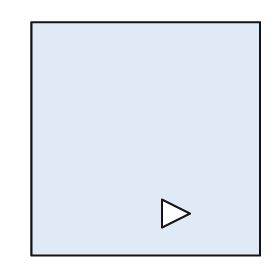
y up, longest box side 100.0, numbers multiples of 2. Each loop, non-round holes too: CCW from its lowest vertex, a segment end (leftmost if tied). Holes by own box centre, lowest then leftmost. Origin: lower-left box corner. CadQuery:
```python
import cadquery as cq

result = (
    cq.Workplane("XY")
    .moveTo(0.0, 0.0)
    .lineTo(98.0, 0.0)
    .lineTo(98.0, 100.0)
    .lineTo(0.0, 100.0)
    .close()
    .moveTo(56.0, 12.0)
    .lineTo(68.0, 18.0)
    .lineTo(56.0, 24.0)
    .close()
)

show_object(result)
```